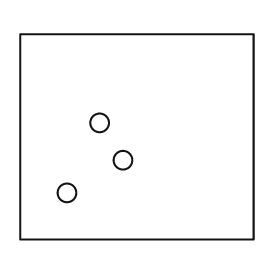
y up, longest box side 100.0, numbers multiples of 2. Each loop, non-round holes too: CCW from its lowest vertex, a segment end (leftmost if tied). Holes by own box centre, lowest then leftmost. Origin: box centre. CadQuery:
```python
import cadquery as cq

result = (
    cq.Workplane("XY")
    .moveTo(-50.0, -44.0)
    .lineTo(50.0, -44.0)
    .lineTo(50.0, 44.0)
    .lineTo(-50.0, 44.0)
    .close()
    .moveTo(-30.0, -24.0)
    .circle(4.0)
    .moveTo(-6.0, -10.0)
    .circle(4.0)
    .moveTo(-16.0, 6.0)
    .circle(4.0)
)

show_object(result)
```